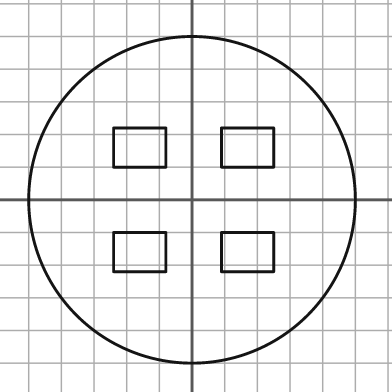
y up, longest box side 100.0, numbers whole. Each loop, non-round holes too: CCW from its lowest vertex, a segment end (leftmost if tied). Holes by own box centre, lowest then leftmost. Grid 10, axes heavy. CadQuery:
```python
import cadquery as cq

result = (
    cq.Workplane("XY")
    .moveTo(0.0, 0.0)
    .circle(50.0)
    .moveTo(-24.0, -22.0)
    .lineTo(-8.0, -22.0)
    .lineTo(-8.0, -10.0)
    .lineTo(-24.0, -10.0)
    .close()
    .moveTo(9.0, -22.0)
    .lineTo(25.0, -22.0)
    .lineTo(25.0, -10.0)
    .lineTo(9.0, -10.0)
    .close()
    .moveTo(-24.0, 10.0)
    .lineTo(-8.0, 10.0)
    .lineTo(-8.0, 22.0)
    .lineTo(-24.0, 22.0)
    .close()
    .moveTo(9.0, 10.0)
    .lineTo(25.0, 10.0)
    .lineTo(25.0, 22.0)
    .lineTo(9.0, 22.0)
    .close()
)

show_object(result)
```